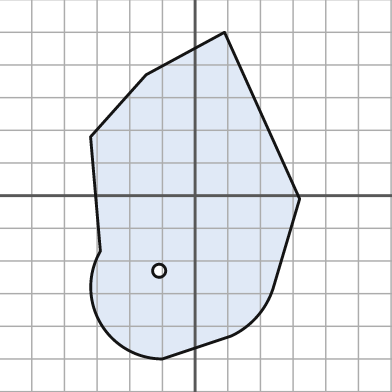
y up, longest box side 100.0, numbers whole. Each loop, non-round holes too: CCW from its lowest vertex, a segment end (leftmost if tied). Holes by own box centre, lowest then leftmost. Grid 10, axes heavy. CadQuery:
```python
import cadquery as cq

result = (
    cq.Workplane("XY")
    .moveTo(-10.0, -50.0)
    .lineTo(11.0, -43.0)
    .threePointArc((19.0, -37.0), (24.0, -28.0))
    .lineTo(32.0, -1.0)
    .lineTo(9.0, 50.0)
    .lineTo(-15.0, 37.0)
    .lineTo(-32.0, 18.0)
    .lineTo(-29.0, -17.0)
    .threePointArc((-29.0, -39.0), (-10.0, -50.0))
    .close()
    .moveTo(-11.0, -23.0)
    .circle(2.0)
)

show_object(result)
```